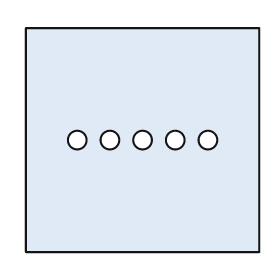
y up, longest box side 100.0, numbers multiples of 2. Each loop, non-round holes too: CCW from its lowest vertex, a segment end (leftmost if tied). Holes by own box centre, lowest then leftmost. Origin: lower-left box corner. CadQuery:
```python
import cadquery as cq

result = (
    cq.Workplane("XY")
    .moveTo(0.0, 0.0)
    .lineTo(100.0, 0.0)
    .lineTo(100.0, 96.0)
    .lineTo(0.0, 96.0)
    .close()
    .moveTo(22.0, 48.0)
    .circle(4.0)
    .moveTo(36.0, 48.0)
    .circle(4.0)
    .moveTo(50.0, 48.0)
    .circle(4.0)
    .moveTo(64.0, 48.0)
    .circle(4.0)
    .moveTo(78.0, 48.0)
    .circle(4.0)
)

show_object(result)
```